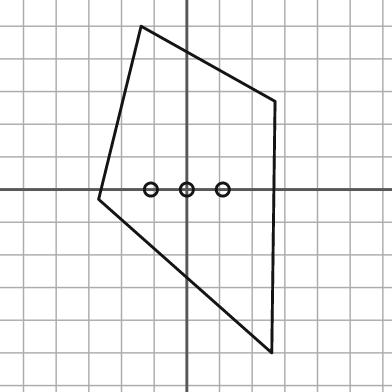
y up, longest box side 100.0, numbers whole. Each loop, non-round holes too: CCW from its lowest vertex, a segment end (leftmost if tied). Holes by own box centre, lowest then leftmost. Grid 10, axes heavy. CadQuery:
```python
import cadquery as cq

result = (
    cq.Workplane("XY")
    .moveTo(26.0, -50.0)
    .lineTo(27.0, 27.0)
    .lineTo(-14.0, 50.0)
    .lineTo(-27.0, -3.0)
    .close()
    .moveTo(-11.0, 0.0)
    .circle(2.0)
    .moveTo(0.0, 0.0)
    .circle(2.0)
    .moveTo(11.0, 0.0)
    .circle(2.0)
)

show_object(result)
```